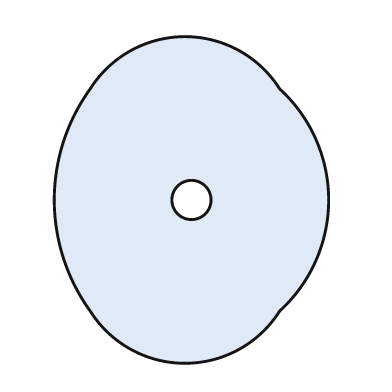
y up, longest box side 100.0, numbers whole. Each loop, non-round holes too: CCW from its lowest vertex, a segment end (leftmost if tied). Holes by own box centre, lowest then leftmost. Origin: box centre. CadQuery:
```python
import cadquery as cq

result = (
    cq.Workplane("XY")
    .moveTo(-31.0, -34.0)
    .threePointArc((-2.0, -50.0), (27.0, -34.0))
    .threePointArc((42.0, 0.0), (27.0, 34.0))
    .threePointArc((-2.0, 50.0), (-31.0, 34.0))
    .threePointArc((-42.0, 0.0), (-31.0, -34.0))
    .close()
    .moveTo(0.0, 0.0)
    .circle(6.0)
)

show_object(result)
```